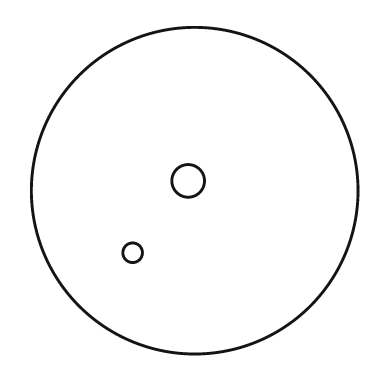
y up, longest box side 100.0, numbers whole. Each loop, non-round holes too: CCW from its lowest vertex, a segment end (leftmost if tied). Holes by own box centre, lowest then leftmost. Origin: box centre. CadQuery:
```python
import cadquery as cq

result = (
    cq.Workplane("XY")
    .moveTo(0.0, 0.0)
    .circle(50.0)
    .moveTo(-19.0, -19.0)
    .circle(3.0)
    .moveTo(-2.0, 3.0)
    .circle(5.0)
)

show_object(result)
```